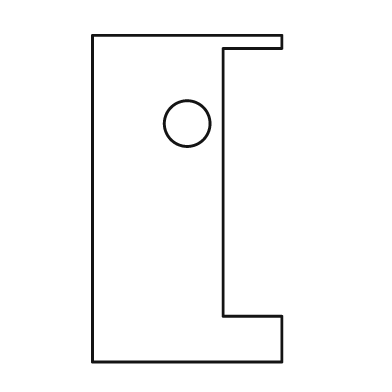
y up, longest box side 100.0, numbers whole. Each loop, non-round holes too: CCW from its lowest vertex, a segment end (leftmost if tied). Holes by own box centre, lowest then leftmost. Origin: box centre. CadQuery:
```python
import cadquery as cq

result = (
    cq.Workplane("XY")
    .moveTo(-29.0, -50.0)
    .lineTo(29.0, -50.0)
    .lineTo(29.0, -36.0)
    .lineTo(11.0, -36.0)
    .lineTo(11.0, 46.0)
    .lineTo(29.0, 46.0)
    .lineTo(29.0, 50.0)
    .lineTo(-29.0, 50.0)
    .close()
    .moveTo(0.0, 23.0)
    .circle(7.0)
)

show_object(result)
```